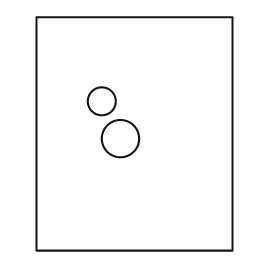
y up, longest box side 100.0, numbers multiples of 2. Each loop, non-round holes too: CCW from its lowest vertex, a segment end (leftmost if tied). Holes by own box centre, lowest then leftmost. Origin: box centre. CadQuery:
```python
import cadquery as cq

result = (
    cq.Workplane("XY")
    .moveTo(-42.0, -50.0)
    .lineTo(42.0, -50.0)
    .lineTo(42.0, 50.0)
    .lineTo(-42.0, 50.0)
    .close()
    .moveTo(-6.0, -2.0)
    .circle(8.0)
    .moveTo(-14.0, 14.0)
    .circle(6.0)
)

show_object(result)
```